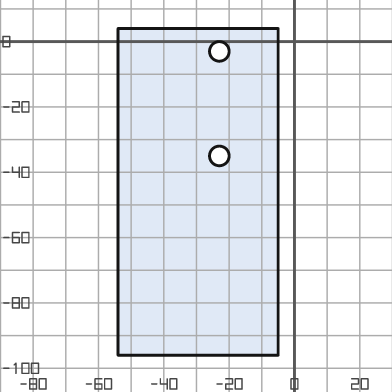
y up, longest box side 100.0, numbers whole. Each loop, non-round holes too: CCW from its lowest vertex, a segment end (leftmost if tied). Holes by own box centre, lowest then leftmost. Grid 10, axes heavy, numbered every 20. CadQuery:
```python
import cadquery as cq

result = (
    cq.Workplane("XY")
    .moveTo(-54.0, -96.0)
    .lineTo(-5.0, -96.0)
    .lineTo(-5.0, 4.0)
    .lineTo(-54.0, 4.0)
    .close()
    .moveTo(-23.0, -35.0)
    .circle(3.0)
    .moveTo(-23.0, -3.0)
    .circle(3.0)
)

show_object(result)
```